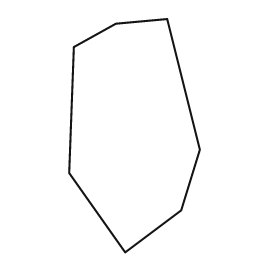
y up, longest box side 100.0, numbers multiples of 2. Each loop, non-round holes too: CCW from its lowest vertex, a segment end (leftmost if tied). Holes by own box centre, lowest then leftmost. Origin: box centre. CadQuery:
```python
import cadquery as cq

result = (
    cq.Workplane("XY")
    .moveTo(-4.0, -50.0)
    .lineTo(20.0, -32.0)
    .lineTo(28.0, -6.0)
    .lineTo(14.0, 50.0)
    .lineTo(-8.0, 48.0)
    .lineTo(-26.0, 38.0)
    .lineTo(-28.0, -16.0)
    .close()
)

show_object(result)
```